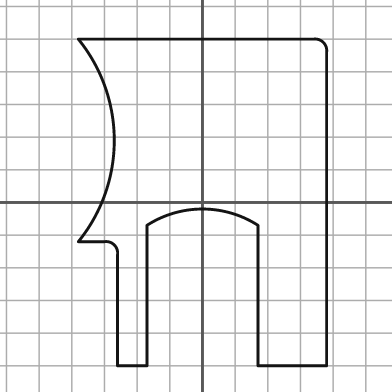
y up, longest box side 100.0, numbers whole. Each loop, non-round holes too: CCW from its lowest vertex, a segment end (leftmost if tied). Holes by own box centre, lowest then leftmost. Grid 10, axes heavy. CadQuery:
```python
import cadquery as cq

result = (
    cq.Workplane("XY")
    .moveTo(-26.0, -50.0)
    .lineTo(-17.0, -50.0)
    .lineTo(-17.0, -7.0)
    .threePointArc((0.0, -2.0), (17.0, -7.0))
    .lineTo(17.0, -50.0)
    .lineTo(38.0, -50.0)
    .lineTo(38.0, 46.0)
    .threePointArc((37.0, 49.0), (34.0, 50.0))
    .lineTo(-38.0, 50.0)
    .threePointArc((-27.0, 19.0), (-38.0, -12.0))
    .lineTo(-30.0, -12.0)
    .threePointArc((-27.0, -13.0), (-26.0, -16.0))
    .close()
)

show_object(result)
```